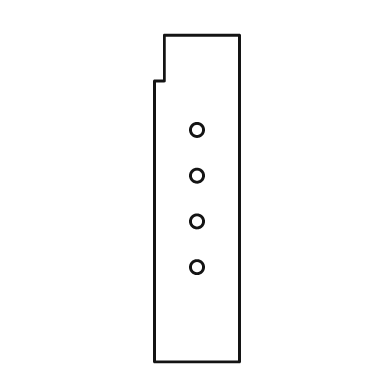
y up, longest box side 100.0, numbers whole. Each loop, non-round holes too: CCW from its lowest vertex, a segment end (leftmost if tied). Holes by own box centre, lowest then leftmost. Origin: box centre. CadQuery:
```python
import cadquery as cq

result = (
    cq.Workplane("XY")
    .moveTo(-13.0, -50.0)
    .lineTo(13.0, -50.0)
    .lineTo(13.0, 50.0)
    .lineTo(-10.0, 50.0)
    .lineTo(-10.0, 36.0)
    .lineTo(-13.0, 36.0)
    .close()
    .moveTo(0.0, -21.0)
    .circle(2.0)
    .moveTo(0.0, -7.0)
    .circle(2.0)
    .moveTo(0.0, 7.0)
    .circle(2.0)
    .moveTo(0.0, 21.0)
    .circle(2.0)
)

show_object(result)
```